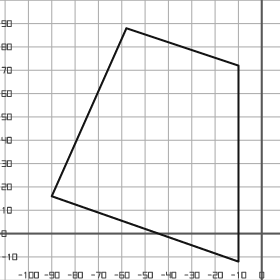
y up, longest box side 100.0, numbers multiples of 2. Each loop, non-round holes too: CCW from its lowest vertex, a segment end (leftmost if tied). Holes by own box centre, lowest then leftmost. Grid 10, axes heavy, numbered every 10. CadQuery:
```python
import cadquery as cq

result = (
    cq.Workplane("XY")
    .moveTo(-10.0, -12.0)
    .lineTo(-10.0, 72.0)
    .lineTo(-58.0, 88.0)
    .lineTo(-90.0, 16.0)
    .close()
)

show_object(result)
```